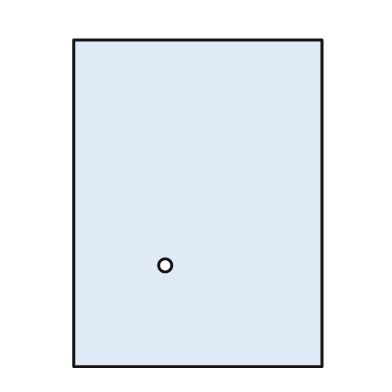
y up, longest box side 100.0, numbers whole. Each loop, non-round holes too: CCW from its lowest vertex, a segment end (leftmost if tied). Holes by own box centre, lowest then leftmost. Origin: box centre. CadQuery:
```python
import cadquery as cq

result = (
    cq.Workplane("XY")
    .moveTo(-38.0, -50.0)
    .lineTo(38.0, -50.0)
    .lineTo(38.0, 50.0)
    .lineTo(-38.0, 50.0)
    .close()
    .moveTo(-10.0, -19.0)
    .circle(2.0)
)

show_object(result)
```